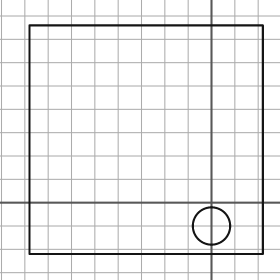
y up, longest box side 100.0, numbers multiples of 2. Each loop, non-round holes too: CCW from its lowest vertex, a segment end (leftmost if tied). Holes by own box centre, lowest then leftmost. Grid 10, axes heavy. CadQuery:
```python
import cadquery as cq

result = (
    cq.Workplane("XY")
    .moveTo(-78.0, -22.0)
    .lineTo(22.0, -22.0)
    .lineTo(22.0, 76.0)
    .lineTo(-78.0, 76.0)
    .close()
    .moveTo(0.0, -10.0)
    .circle(8.0)
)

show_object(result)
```